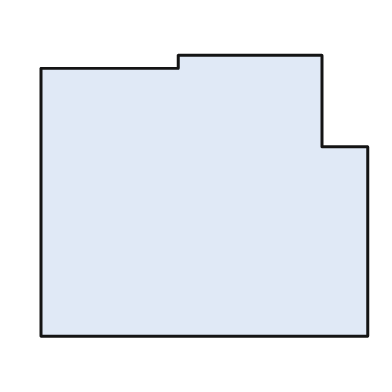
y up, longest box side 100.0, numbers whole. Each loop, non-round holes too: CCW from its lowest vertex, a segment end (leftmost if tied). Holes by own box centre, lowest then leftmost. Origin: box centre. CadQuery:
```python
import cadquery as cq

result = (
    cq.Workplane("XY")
    .moveTo(-50.0, -43.0)
    .lineTo(50.0, -43.0)
    .lineTo(50.0, 15.0)
    .lineTo(36.0, 15.0)
    .lineTo(36.0, 43.0)
    .lineTo(-8.0, 43.0)
    .lineTo(-8.0, 39.0)
    .lineTo(-50.0, 39.0)
    .close()
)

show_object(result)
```